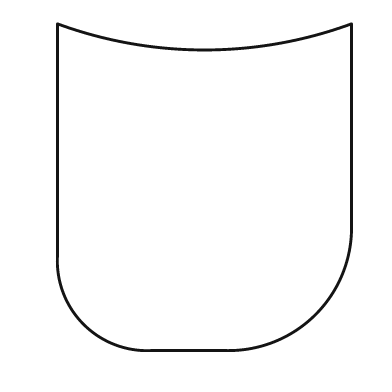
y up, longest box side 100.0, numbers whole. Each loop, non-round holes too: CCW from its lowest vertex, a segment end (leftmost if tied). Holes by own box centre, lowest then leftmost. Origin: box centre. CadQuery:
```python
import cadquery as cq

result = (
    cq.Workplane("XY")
    .moveTo(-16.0, -50.0)
    .lineTo(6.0, -50.0)
    .threePointArc((34.0, -39.0), (45.0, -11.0))
    .lineTo(45.0, 50.0)
    .threePointArc((0.0, 42.0), (-45.0, 50.0))
    .lineTo(-45.0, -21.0)
    .threePointArc((-37.0, -42.0), (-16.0, -50.0))
    .close()
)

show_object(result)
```